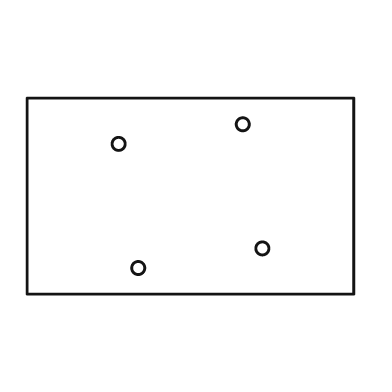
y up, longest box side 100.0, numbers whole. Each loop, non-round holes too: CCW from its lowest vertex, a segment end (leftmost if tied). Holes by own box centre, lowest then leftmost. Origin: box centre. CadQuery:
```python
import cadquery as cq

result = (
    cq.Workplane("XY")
    .moveTo(-50.0, -30.0)
    .lineTo(50.0, -30.0)
    .lineTo(50.0, 30.0)
    .lineTo(-50.0, 30.0)
    .close()
    .moveTo(-16.0, -22.0)
    .circle(2.0)
    .moveTo(22.0, -16.0)
    .circle(2.0)
    .moveTo(-22.0, 16.0)
    .circle(2.0)
    .moveTo(16.0, 22.0)
    .circle(2.0)
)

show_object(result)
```